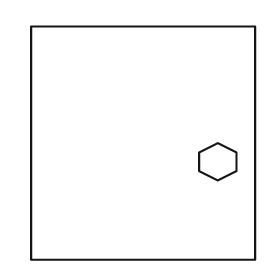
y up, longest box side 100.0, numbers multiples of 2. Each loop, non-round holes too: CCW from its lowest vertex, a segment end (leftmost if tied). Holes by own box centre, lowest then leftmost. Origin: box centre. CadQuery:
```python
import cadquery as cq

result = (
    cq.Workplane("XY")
    .moveTo(-48.0, -50.0)
    .lineTo(48.0, -50.0)
    .lineTo(48.0, 50.0)
    .lineTo(-48.0, 50.0)
    .close()
    .moveTo(32.0, -16.0)
    .lineTo(40.0, -12.0)
    .lineTo(40.0, -4.0)
    .lineTo(32.0, 0.0)
    .lineTo(24.0, -4.0)
    .lineTo(24.0, -12.0)
    .close()
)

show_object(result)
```